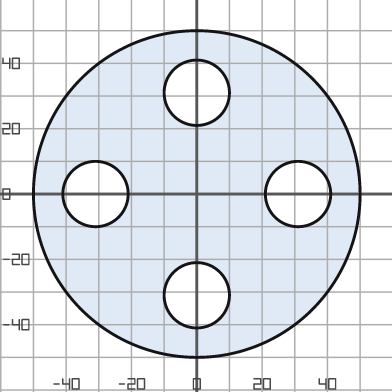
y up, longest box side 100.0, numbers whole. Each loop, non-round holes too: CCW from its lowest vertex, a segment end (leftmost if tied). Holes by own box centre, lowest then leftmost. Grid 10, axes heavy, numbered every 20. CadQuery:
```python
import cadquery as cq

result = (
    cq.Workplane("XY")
    .moveTo(0.0, 0.0)
    .circle(50.0)
    .moveTo(0.0, -31.0)
    .circle(10.0)
    .moveTo(-31.0, 0.0)
    .circle(10.0)
    .moveTo(31.0, 0.0)
    .circle(10.0)
    .moveTo(0.0, 31.0)
    .circle(10.0)
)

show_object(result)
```